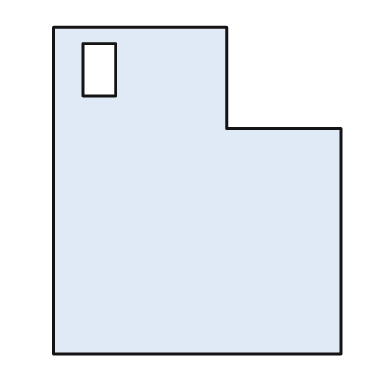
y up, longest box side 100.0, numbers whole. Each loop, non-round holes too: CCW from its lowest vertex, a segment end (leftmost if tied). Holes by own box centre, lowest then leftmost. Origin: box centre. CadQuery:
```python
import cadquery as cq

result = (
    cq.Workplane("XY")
    .moveTo(-44.0, -50.0)
    .lineTo(44.0, -50.0)
    .lineTo(44.0, 19.0)
    .lineTo(9.0, 19.0)
    .lineTo(9.0, 50.0)
    .lineTo(-44.0, 50.0)
    .close()
    .moveTo(-35.0, 29.0)
    .lineTo(-25.0, 29.0)
    .lineTo(-25.0, 45.0)
    .lineTo(-35.0, 45.0)
    .close()
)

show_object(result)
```